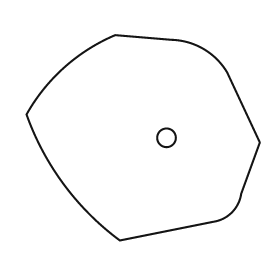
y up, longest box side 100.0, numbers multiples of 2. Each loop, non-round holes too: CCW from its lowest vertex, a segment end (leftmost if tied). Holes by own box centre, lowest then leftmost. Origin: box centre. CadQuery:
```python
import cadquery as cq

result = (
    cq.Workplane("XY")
    .moveTo(-10.0, -44.0)
    .lineTo(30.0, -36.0)
    .threePointArc((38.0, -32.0), (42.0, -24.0))
    .lineTo(50.0, -2.0)
    .lineTo(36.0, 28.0)
    .threePointArc((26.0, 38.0), (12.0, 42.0))
    .lineTo(-12.0, 44.0)
    .threePointArc((-34.0, 30.0), (-50.0, 10.0))
    .threePointArc((-34.0, -20.0), (-10.0, -44.0))
    .close()
    .moveTo(10.0, 0.0)
    .circle(4.0)
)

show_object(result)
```